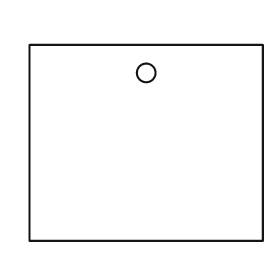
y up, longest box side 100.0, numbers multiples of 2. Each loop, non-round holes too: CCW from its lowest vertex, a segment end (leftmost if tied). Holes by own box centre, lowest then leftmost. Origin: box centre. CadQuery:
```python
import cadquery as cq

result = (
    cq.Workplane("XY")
    .moveTo(-50.0, -42.0)
    .lineTo(50.0, -42.0)
    .lineTo(50.0, 42.0)
    .lineTo(-50.0, 42.0)
    .close()
    .moveTo(0.0, 30.0)
    .circle(4.0)
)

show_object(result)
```